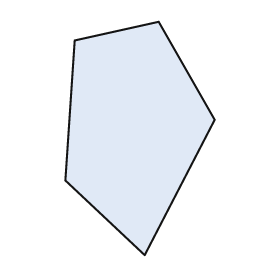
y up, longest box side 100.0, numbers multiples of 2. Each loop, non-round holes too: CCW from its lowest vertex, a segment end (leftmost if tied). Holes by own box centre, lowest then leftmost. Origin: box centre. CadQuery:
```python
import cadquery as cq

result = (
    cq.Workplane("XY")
    .moveTo(2.0, -50.0)
    .lineTo(32.0, 8.0)
    .lineTo(8.0, 50.0)
    .lineTo(-28.0, 42.0)
    .lineTo(-32.0, -18.0)
    .close()
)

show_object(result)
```